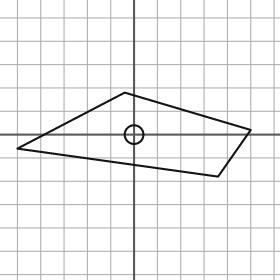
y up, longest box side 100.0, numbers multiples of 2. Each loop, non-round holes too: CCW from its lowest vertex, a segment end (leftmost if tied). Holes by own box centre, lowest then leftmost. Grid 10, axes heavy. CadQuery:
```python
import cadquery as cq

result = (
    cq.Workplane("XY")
    .moveTo(36.0, -18.0)
    .lineTo(50.0, 2.0)
    .lineTo(-4.0, 18.0)
    .lineTo(-50.0, -6.0)
    .close()
    .moveTo(0.0, 0.0)
    .circle(4.0)
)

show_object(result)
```